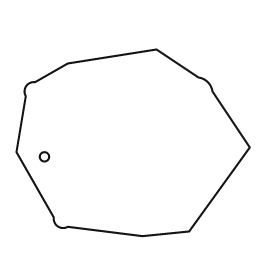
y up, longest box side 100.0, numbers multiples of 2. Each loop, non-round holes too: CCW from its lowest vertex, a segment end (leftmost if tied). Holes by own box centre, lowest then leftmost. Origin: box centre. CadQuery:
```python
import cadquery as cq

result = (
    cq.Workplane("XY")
    .moveTo(4.0, -40.0)
    .lineTo(24.0, -38.0)
    .lineTo(50.0, -2.0)
    .lineTo(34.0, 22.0)
    .threePointArc((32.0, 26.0), (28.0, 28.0))
    .lineTo(10.0, 40.0)
    .lineTo(-28.0, 34.0)
    .lineTo(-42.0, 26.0)
    .threePointArc((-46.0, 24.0), (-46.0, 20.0))
    .lineTo(-50.0, -4.0)
    .lineTo(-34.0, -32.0)
    .threePointArc((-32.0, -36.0), (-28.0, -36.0))
    .close()
    .moveTo(-38.0, -6.0)
    .circle(2.0)
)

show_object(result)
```